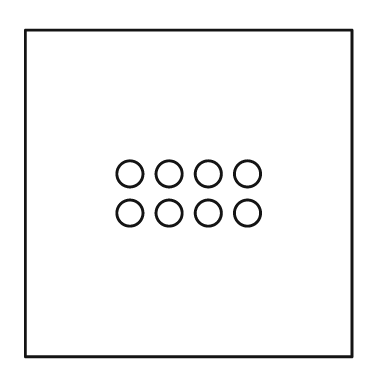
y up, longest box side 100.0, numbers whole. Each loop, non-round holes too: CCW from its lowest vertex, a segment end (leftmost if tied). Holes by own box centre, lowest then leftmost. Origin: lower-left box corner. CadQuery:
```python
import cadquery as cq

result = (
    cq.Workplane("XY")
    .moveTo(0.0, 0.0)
    .lineTo(100.0, 0.0)
    .lineTo(100.0, 100.0)
    .lineTo(0.0, 100.0)
    .close()
    .moveTo(32.0, 44.0)
    .circle(4.0)
    .moveTo(44.0, 44.0)
    .circle(4.0)
    .moveTo(56.0, 44.0)
    .circle(4.0)
    .moveTo(68.0, 44.0)
    .circle(4.0)
    .moveTo(32.0, 56.0)
    .circle(4.0)
    .moveTo(44.0, 56.0)
    .circle(4.0)
    .moveTo(56.0, 56.0)
    .circle(4.0)
    .moveTo(68.0, 56.0)
    .circle(4.0)
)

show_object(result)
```